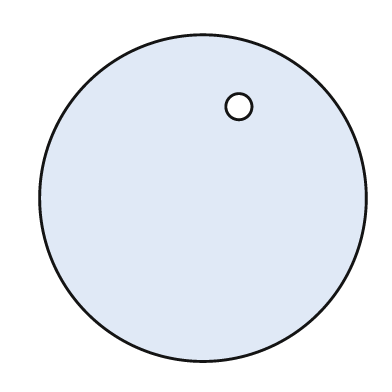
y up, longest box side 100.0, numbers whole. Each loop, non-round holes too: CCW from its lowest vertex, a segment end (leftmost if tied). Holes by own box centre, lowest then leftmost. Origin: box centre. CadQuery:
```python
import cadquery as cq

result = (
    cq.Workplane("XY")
    .moveTo(0.0, 0.0)
    .circle(50.0)
    .moveTo(11.0, 28.0)
    .circle(4.0)
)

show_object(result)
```